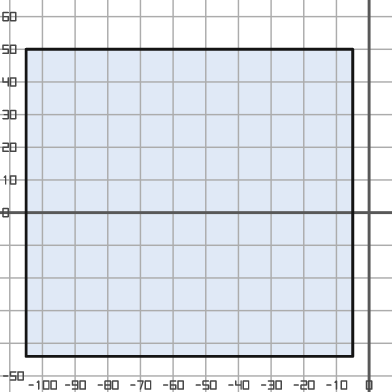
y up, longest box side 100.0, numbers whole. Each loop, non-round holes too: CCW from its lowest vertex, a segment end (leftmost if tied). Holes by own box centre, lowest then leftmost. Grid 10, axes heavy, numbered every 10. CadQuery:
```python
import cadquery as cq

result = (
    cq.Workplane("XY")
    .moveTo(-105.0, -44.0)
    .lineTo(-5.0, -44.0)
    .lineTo(-5.0, 50.0)
    .lineTo(-105.0, 50.0)
    .close()
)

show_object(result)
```